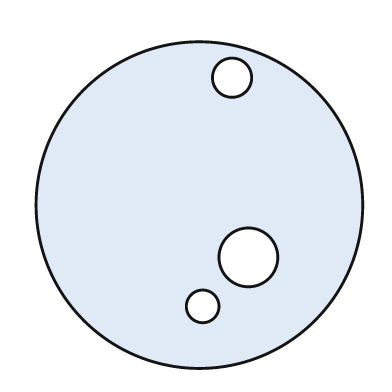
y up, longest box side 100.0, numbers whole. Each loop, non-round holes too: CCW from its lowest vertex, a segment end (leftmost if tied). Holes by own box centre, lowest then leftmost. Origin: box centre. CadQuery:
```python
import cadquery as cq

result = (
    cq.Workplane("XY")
    .moveTo(0.0, 0.0)
    .circle(50.0)
    .moveTo(1.0, -31.0)
    .circle(5.0)
    .moveTo(15.0, -16.0)
    .circle(9.0)
    .moveTo(10.0, 39.0)
    .circle(6.0)
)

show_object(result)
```